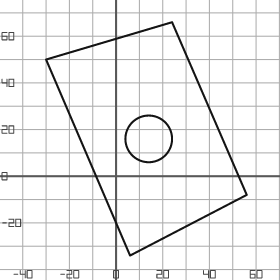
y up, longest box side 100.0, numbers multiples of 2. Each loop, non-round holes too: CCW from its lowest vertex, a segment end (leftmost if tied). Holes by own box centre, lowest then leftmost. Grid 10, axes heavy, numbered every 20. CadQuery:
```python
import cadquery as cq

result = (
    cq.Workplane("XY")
    .moveTo(6.0, -34.0)
    .lineTo(56.0, -8.0)
    .lineTo(24.0, 66.0)
    .lineTo(-30.0, 50.0)
    .close()
    .moveTo(14.0, 16.0)
    .circle(10.0)
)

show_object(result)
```